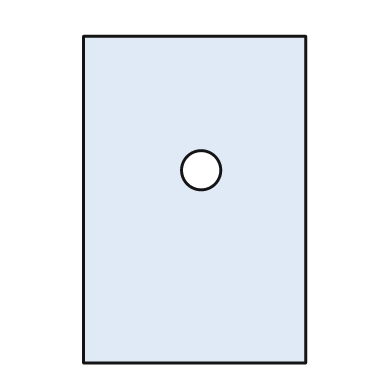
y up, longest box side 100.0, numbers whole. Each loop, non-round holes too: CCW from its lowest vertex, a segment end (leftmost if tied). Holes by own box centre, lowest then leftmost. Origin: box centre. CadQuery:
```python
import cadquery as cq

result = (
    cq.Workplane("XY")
    .moveTo(-34.0, -50.0)
    .lineTo(34.0, -50.0)
    .lineTo(34.0, 50.0)
    .lineTo(-34.0, 50.0)
    .close()
    .moveTo(2.0, 9.0)
    .circle(6.0)
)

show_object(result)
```